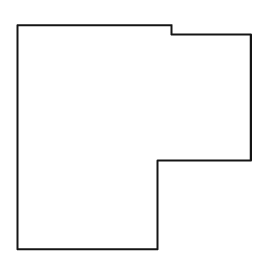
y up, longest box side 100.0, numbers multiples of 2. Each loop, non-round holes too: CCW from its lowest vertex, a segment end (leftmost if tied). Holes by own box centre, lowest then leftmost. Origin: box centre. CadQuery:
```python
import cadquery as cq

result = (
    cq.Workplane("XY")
    .moveTo(-50.0, -48.0)
    .lineTo(10.0, -48.0)
    .lineTo(10.0, -10.0)
    .lineTo(50.0, -10.0)
    .lineTo(50.0, 44.0)
    .lineTo(16.0, 44.0)
    .lineTo(16.0, 48.0)
    .lineTo(-50.0, 48.0)
    .close()
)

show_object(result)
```